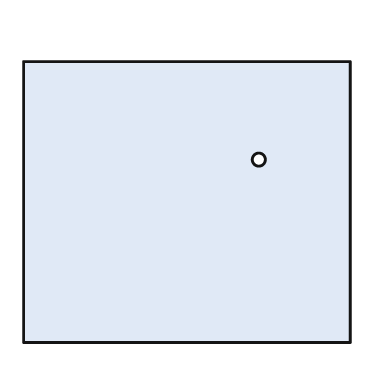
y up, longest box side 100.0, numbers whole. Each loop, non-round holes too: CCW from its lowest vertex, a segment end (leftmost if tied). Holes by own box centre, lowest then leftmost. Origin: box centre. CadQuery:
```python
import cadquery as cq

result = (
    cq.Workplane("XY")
    .moveTo(-50.0, -43.0)
    .lineTo(50.0, -43.0)
    .lineTo(50.0, 43.0)
    .lineTo(-50.0, 43.0)
    .close()
    .moveTo(22.0, 13.0)
    .circle(2.0)
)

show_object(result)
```